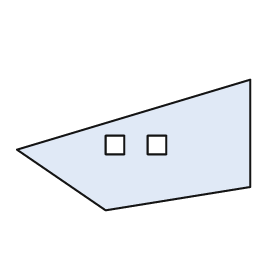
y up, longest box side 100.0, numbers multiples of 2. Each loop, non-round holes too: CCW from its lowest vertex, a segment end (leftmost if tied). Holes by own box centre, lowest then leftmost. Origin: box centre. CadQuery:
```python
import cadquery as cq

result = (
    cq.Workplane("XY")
    .moveTo(-12.0, -28.0)
    .lineTo(50.0, -18.0)
    .lineTo(50.0, 28.0)
    .lineTo(-50.0, -2.0)
    .close()
    .moveTo(-12.0, -4.0)
    .lineTo(-4.0, -4.0)
    .lineTo(-4.0, 4.0)
    .lineTo(-12.0, 4.0)
    .close()
    .moveTo(6.0, -4.0)
    .lineTo(14.0, -4.0)
    .lineTo(14.0, 4.0)
    .lineTo(6.0, 4.0)
    .close()
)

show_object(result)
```